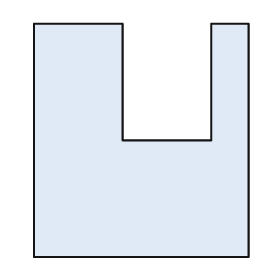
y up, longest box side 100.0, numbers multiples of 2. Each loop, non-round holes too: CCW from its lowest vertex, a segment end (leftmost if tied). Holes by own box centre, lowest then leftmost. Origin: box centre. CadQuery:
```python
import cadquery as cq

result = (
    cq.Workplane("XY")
    .moveTo(-46.0, -50.0)
    .lineTo(46.0, -50.0)
    .lineTo(46.0, 50.0)
    .lineTo(30.0, 50.0)
    .lineTo(30.0, 0.0)
    .lineTo(-8.0, 0.0)
    .lineTo(-8.0, 50.0)
    .lineTo(-46.0, 50.0)
    .close()
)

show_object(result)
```